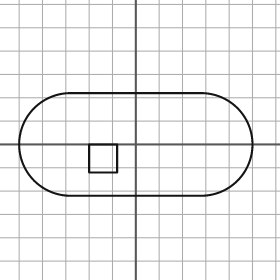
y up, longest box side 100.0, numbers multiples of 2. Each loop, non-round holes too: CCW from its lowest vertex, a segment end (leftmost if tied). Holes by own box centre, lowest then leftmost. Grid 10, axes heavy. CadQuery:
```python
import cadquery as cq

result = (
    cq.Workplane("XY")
    .moveTo(-28.0, -22.0)
    .lineTo(28.0, -22.0)
    .threePointArc((50.0, 0.0), (28.0, 22.0))
    .lineTo(-28.0, 22.0)
    .threePointArc((-50.0, 0.0), (-28.0, -22.0))
    .close()
    .moveTo(-20.0, -12.0)
    .lineTo(-8.0, -12.0)
    .lineTo(-8.0, 0.0)
    .lineTo(-20.0, 0.0)
    .close()
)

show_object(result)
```